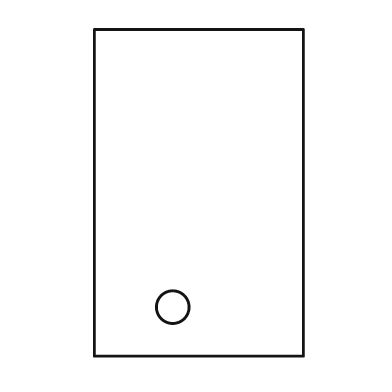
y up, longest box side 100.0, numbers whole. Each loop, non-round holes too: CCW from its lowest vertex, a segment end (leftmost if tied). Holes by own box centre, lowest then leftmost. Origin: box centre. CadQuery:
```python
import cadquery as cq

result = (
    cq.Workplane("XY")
    .moveTo(-32.0, -50.0)
    .lineTo(32.0, -50.0)
    .lineTo(32.0, 50.0)
    .lineTo(-32.0, 50.0)
    .close()
    .moveTo(-8.0, -35.0)
    .circle(5.0)
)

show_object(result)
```